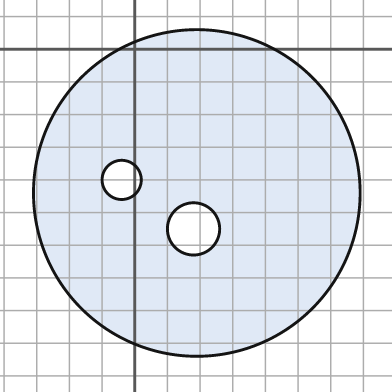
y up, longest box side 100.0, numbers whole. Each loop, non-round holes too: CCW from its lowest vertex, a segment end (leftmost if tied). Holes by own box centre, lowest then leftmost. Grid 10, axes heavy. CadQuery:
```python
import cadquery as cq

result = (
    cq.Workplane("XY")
    .moveTo(19.0, -44.0)
    .circle(50.0)
    .moveTo(18.0, -55.0)
    .circle(8.0)
    .moveTo(-4.0, -40.0)
    .circle(6.0)
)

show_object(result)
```